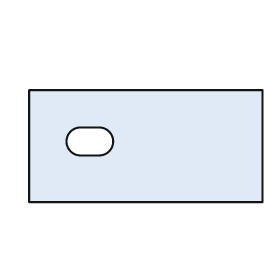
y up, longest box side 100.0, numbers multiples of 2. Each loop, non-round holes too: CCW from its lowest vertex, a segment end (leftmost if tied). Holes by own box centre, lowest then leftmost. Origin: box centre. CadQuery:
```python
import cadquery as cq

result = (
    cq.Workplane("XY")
    .moveTo(-50.0, -24.0)
    .lineTo(50.0, -24.0)
    .lineTo(50.0, 24.0)
    .lineTo(-50.0, 24.0)
    .close()
    .moveTo(-28.0, -4.0)
    .lineTo(-20.0, -4.0)
    .threePointArc((-14.0, 2.0), (-20.0, 8.0))
    .lineTo(-28.0, 8.0)
    .threePointArc((-34.0, 2.0), (-28.0, -4.0))
    .close()
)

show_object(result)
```